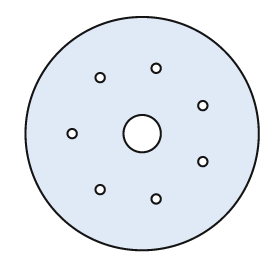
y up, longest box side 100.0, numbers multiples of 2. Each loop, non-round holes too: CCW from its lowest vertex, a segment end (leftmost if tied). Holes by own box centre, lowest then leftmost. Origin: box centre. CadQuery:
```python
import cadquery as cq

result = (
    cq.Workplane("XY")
    .moveTo(0.0, 0.0)
    .circle(50.0)
    .moveTo(6.0, -28.0)
    .circle(2.0)
    .moveTo(-18.0, -24.0)
    .circle(2.0)
    .moveTo(26.0, -12.0)
    .circle(2.0)
    .moveTo(-30.0, 0.0)
    .circle(2.0)
    .moveTo(0.0, 0.0)
    .circle(8.0)
    .moveTo(26.0, 12.0)
    .circle(2.0)
    .moveTo(-18.0, 24.0)
    .circle(2.0)
    .moveTo(6.0, 28.0)
    .circle(2.0)
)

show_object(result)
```